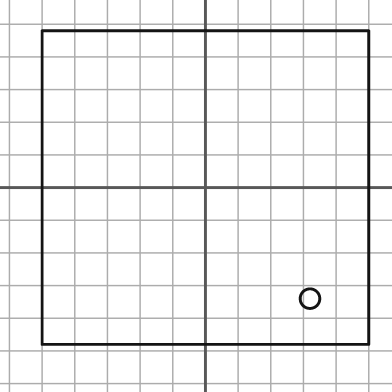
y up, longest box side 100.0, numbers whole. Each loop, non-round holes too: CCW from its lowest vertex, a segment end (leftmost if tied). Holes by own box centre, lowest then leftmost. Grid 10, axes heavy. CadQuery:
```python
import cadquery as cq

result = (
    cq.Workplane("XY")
    .moveTo(-50.0, -48.0)
    .lineTo(50.0, -48.0)
    .lineTo(50.0, 48.0)
    .lineTo(-50.0, 48.0)
    .close()
    .moveTo(32.0, -34.0)
    .circle(3.0)
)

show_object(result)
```